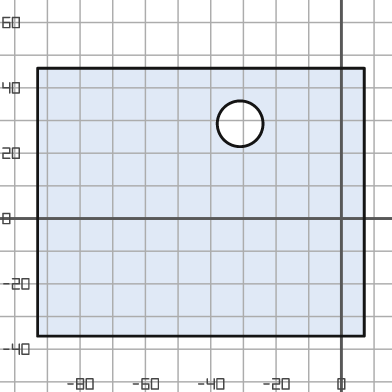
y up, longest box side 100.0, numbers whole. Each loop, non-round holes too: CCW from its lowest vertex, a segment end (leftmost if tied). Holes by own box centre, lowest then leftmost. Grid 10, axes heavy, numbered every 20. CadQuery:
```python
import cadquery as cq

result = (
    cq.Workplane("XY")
    .moveTo(-93.0, -36.0)
    .lineTo(7.0, -36.0)
    .lineTo(7.0, 46.0)
    .lineTo(-93.0, 46.0)
    .close()
    .moveTo(-31.0, 29.0)
    .circle(7.0)
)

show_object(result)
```